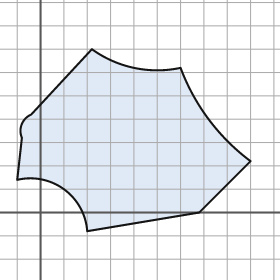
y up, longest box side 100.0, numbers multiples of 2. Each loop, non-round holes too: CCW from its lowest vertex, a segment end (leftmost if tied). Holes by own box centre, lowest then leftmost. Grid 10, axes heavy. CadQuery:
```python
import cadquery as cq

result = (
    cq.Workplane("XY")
    .moveTo(20.0, -8.0)
    .lineTo(68.0, 0.0)
    .lineTo(90.0, 22.0)
    .threePointArc((72.0, 40.0), (60.0, 62.0))
    .threePointArc((40.0, 62.0), (22.0, 70.0))
    .lineTo(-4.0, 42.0)
    .threePointArc((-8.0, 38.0), (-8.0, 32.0))
    .lineTo(-10.0, 14.0)
    .threePointArc((10.0, 10.0), (20.0, -8.0))
    .close()
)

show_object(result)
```